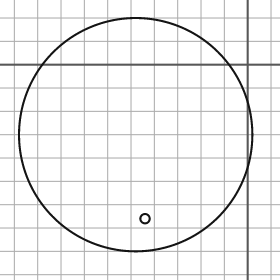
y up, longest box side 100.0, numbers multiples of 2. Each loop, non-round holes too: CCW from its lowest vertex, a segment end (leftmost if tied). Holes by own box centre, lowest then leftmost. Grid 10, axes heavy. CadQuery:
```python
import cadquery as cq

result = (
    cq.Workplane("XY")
    .moveTo(-48.0, -30.0)
    .circle(50.0)
    .moveTo(-44.0, -66.0)
    .circle(2.0)
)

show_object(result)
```